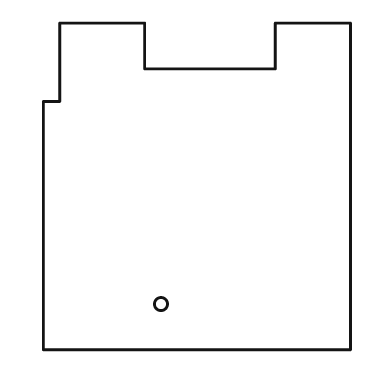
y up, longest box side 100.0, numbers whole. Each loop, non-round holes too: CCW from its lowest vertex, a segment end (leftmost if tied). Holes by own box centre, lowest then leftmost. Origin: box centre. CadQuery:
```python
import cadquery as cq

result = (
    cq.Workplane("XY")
    .moveTo(-47.0, -50.0)
    .lineTo(47.0, -50.0)
    .lineTo(47.0, 50.0)
    .lineTo(24.0, 50.0)
    .lineTo(24.0, 36.0)
    .lineTo(-16.0, 36.0)
    .lineTo(-16.0, 50.0)
    .lineTo(-42.0, 50.0)
    .lineTo(-42.0, 26.0)
    .lineTo(-47.0, 26.0)
    .close()
    .moveTo(-11.0, -36.0)
    .circle(2.0)
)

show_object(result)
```